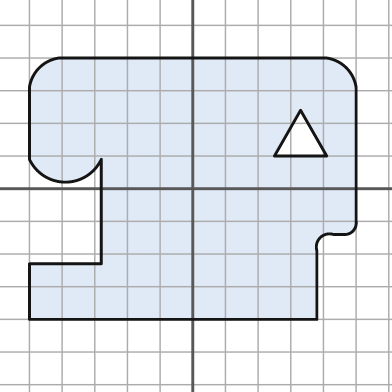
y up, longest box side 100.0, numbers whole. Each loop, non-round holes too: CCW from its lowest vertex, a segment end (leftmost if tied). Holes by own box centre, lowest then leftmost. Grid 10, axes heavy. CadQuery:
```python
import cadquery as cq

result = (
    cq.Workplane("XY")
    .moveTo(-50.0, -40.0)
    .lineTo(38.0, -40.0)
    .lineTo(38.0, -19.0)
    .threePointArc((39.0, -15.0), (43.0, -14.0))
    .lineTo(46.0, -14.0)
    .threePointArc((49.0, -13.0), (50.0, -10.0))
    .lineTo(50.0, 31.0)
    .threePointArc((47.0, 37.0), (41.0, 40.0))
    .lineTo(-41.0, 40.0)
    .threePointArc((-47.0, 37.0), (-50.0, 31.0))
    .lineTo(-50.0, 9.0)
    .threePointArc((-39.0, 2.0), (-28.0, 9.0))
    .lineTo(-28.0, -23.0)
    .lineTo(-50.0, -23.0)
    .close()
    .moveTo(25.0, 10.0)
    .lineTo(41.0, 10.0)
    .lineTo(33.0, 24.0)
    .close()
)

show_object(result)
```